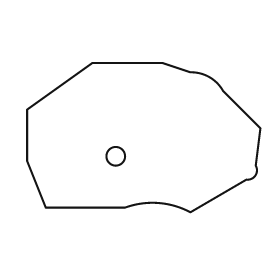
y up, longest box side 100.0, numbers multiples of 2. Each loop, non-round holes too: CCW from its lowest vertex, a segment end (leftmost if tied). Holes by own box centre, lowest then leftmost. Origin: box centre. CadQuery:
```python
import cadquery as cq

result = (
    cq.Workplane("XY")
    .moveTo(20.0, -32.0)
    .lineTo(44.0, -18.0)
    .threePointArc((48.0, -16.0), (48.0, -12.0))
    .lineTo(50.0, 4.0)
    .lineTo(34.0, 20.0)
    .threePointArc((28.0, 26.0), (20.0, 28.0))
    .lineTo(8.0, 32.0)
    .lineTo(-22.0, 32.0)
    .lineTo(-50.0, 12.0)
    .lineTo(-50.0, -10.0)
    .lineTo(-42.0, -30.0)
    .lineTo(-8.0, -30.0)
    .threePointArc((6.0, -28.0), (20.0, -32.0))
    .close()
    .moveTo(-12.0, -8.0)
    .circle(4.0)
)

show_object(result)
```